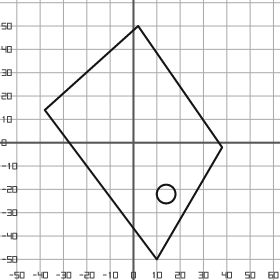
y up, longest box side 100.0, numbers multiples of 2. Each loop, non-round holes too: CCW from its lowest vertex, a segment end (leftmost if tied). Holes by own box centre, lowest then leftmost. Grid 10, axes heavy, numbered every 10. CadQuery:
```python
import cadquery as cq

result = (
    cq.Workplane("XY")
    .moveTo(10.0, -50.0)
    .lineTo(38.0, -2.0)
    .lineTo(2.0, 50.0)
    .lineTo(-38.0, 14.0)
    .close()
    .moveTo(14.0, -22.0)
    .circle(4.0)
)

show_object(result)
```